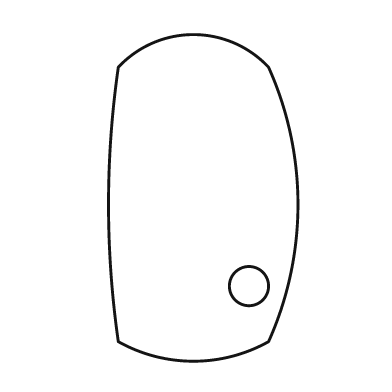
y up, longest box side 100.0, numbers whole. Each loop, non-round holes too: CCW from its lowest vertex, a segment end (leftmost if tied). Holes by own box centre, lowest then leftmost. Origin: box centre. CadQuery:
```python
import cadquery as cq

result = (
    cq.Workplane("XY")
    .moveTo(-26.0, -44.0)
    .threePointArc((-3.0, -50.0), (20.0, -44.0))
    .threePointArc((29.0, -2.0), (20.0, 40.0))
    .threePointArc((-3.0, 50.0), (-26.0, 40.0))
    .threePointArc((-29.0, -2.0), (-26.0, -44.0))
    .close()
    .moveTo(14.0, -27.0)
    .circle(6.0)
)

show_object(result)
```